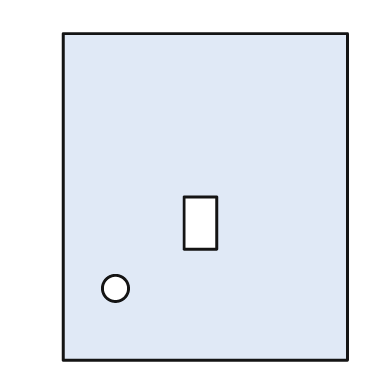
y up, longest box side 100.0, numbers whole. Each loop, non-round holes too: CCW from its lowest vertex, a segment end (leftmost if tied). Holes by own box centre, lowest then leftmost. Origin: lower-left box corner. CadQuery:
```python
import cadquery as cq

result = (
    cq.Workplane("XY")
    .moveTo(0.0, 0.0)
    .lineTo(87.0, 0.0)
    .lineTo(87.0, 100.0)
    .lineTo(0.0, 100.0)
    .close()
    .moveTo(16.0, 22.0)
    .circle(4.0)
    .moveTo(37.0, 34.0)
    .lineTo(47.0, 34.0)
    .lineTo(47.0, 50.0)
    .lineTo(37.0, 50.0)
    .close()
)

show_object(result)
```